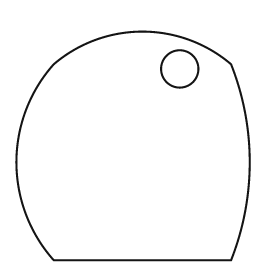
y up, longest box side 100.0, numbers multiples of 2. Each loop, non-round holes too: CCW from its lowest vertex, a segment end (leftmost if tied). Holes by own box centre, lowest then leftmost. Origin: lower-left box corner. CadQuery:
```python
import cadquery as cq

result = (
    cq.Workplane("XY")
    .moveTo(16.0, 0.0)
    .lineTo(92.0, 0.0)
    .threePointArc((100.0, 42.0), (92.0, 84.0))
    .threePointArc((54.0, 98.0), (16.0, 84.0))
    .threePointArc((0.0, 42.0), (16.0, 0.0))
    .close()
    .moveTo(70.0, 82.0)
    .circle(8.0)
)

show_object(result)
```